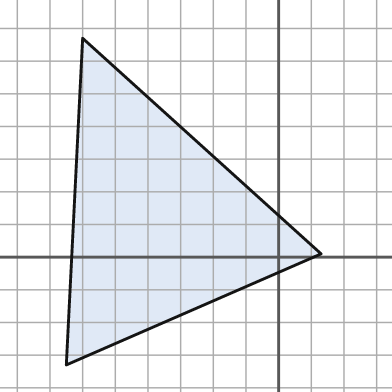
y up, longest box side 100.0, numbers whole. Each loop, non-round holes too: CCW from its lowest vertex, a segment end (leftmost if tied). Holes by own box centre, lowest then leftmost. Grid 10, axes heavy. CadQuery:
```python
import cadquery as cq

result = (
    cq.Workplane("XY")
    .moveTo(-65.0, -33.0)
    .lineTo(13.0, 1.0)
    .lineTo(-60.0, 67.0)
    .close()
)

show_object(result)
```